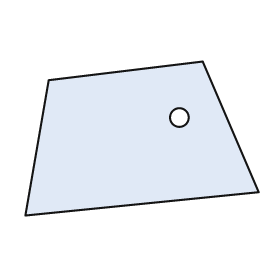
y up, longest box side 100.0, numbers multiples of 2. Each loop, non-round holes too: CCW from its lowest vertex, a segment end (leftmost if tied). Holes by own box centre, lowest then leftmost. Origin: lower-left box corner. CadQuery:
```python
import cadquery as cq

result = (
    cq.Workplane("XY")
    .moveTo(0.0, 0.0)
    .lineTo(100.0, 10.0)
    .lineTo(76.0, 66.0)
    .lineTo(10.0, 58.0)
    .close()
    .moveTo(66.0, 42.0)
    .circle(4.0)
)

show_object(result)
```